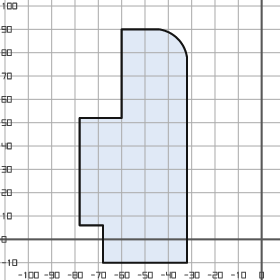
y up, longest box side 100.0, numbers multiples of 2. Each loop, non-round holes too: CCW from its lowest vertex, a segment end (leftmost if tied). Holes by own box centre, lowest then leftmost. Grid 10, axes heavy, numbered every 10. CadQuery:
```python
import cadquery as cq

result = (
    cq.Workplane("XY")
    .moveTo(-68.0, -10.0)
    .lineTo(-32.0, -10.0)
    .lineTo(-32.0, 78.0)
    .threePointArc((-36.0, 86.0), (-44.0, 90.0))
    .lineTo(-60.0, 90.0)
    .lineTo(-60.0, 52.0)
    .lineTo(-78.0, 52.0)
    .lineTo(-78.0, 6.0)
    .lineTo(-68.0, 6.0)
    .close()
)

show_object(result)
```